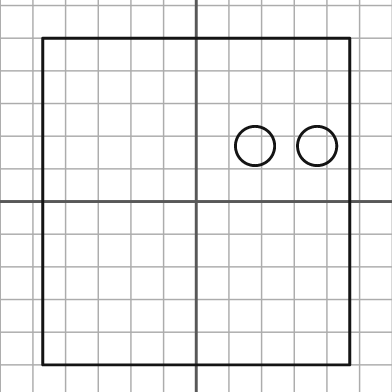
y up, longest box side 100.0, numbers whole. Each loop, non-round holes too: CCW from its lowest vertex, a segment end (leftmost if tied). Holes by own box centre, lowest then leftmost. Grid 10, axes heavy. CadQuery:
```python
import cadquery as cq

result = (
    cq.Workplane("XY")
    .moveTo(-47.0, -50.0)
    .lineTo(47.0, -50.0)
    .lineTo(47.0, 50.0)
    .lineTo(-47.0, 50.0)
    .close()
    .moveTo(18.0, 17.0)
    .circle(6.0)
    .moveTo(37.0, 17.0)
    .circle(6.0)
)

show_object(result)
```